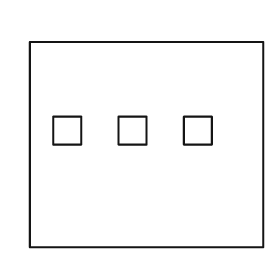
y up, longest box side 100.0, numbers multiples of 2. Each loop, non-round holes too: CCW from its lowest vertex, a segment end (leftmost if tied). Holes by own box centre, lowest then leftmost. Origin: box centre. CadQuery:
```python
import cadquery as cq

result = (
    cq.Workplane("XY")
    .moveTo(-50.0, -44.0)
    .lineTo(50.0, -44.0)
    .lineTo(50.0, 44.0)
    .lineTo(-50.0, 44.0)
    .close()
    .moveTo(-40.0, 0.0)
    .lineTo(-28.0, 0.0)
    .lineTo(-28.0, 12.0)
    .lineTo(-40.0, 12.0)
    .close()
    .moveTo(-12.0, 0.0)
    .lineTo(0.0, 0.0)
    .lineTo(0.0, 12.0)
    .lineTo(-12.0, 12.0)
    .close()
    .moveTo(16.0, 0.0)
    .lineTo(28.0, 0.0)
    .lineTo(28.0, 12.0)
    .lineTo(16.0, 12.0)
    .close()
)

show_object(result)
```